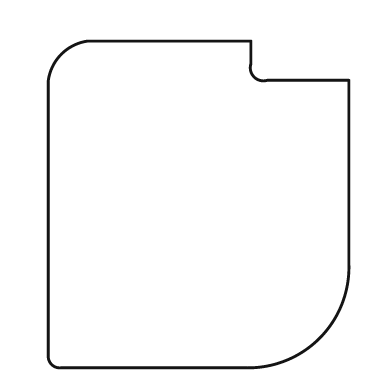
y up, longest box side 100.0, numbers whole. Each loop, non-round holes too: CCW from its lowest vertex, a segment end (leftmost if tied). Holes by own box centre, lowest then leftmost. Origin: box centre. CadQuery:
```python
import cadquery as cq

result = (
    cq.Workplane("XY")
    .moveTo(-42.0, -50.0)
    .lineTo(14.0, -50.0)
    .threePointArc((37.0, -41.0), (46.0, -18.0))
    .lineTo(46.0, 38.0)
    .lineTo(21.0, 38.0)
    .threePointArc((17.0, 39.0), (16.0, 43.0))
    .lineTo(16.0, 50.0)
    .lineTo(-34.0, 50.0)
    .threePointArc((-42.0, 46.0), (-46.0, 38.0))
    .lineTo(-46.0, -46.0)
    .threePointArc((-45.0, -49.0), (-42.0, -50.0))
    .close()
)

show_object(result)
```